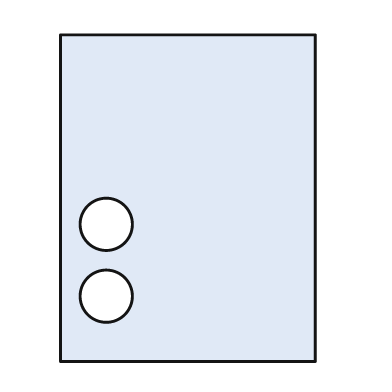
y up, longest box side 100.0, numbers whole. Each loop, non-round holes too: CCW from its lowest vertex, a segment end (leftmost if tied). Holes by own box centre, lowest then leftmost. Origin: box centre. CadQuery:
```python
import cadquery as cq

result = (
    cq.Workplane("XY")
    .moveTo(-39.0, -50.0)
    .lineTo(39.0, -50.0)
    .lineTo(39.0, 50.0)
    .lineTo(-39.0, 50.0)
    .close()
    .moveTo(-25.0, -30.0)
    .circle(8.0)
    .moveTo(-25.0, -8.0)
    .circle(8.0)
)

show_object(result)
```